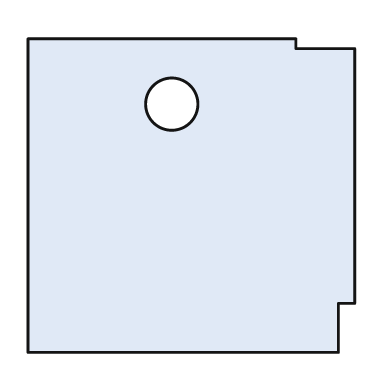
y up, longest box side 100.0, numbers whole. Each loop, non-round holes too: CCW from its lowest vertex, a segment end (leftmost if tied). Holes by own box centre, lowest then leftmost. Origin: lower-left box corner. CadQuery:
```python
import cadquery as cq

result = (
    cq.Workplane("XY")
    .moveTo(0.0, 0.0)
    .lineTo(95.0, 0.0)
    .lineTo(95.0, 15.0)
    .lineTo(100.0, 15.0)
    .lineTo(100.0, 93.0)
    .lineTo(82.0, 93.0)
    .lineTo(82.0, 96.0)
    .lineTo(0.0, 96.0)
    .close()
    .moveTo(44.0, 76.0)
    .circle(8.0)
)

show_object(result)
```